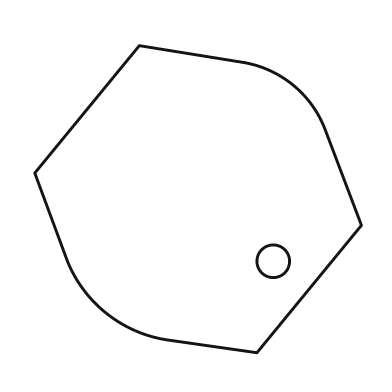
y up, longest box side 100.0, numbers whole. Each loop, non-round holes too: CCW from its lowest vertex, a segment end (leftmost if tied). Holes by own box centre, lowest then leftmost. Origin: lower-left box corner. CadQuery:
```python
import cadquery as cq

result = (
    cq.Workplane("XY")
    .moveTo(68.0, 0.0)
    .lineTo(100.0, 39.0)
    .lineTo(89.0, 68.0)
    .threePointArc((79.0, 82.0), (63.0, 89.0))
    .lineTo(32.0, 94.0)
    .lineTo(0.0, 55.0)
    .lineTo(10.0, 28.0)
    .threePointArc((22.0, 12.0), (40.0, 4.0))
    .close()
    .moveTo(73.0, 28.0)
    .circle(5.0)
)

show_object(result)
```